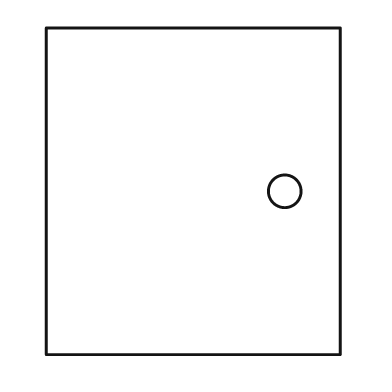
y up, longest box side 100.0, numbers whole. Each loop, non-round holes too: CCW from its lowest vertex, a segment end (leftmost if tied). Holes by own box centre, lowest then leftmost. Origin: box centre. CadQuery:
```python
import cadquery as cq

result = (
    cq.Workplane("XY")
    .moveTo(-45.0, -50.0)
    .lineTo(45.0, -50.0)
    .lineTo(45.0, 50.0)
    .lineTo(-45.0, 50.0)
    .close()
    .moveTo(28.0, 0.0)
    .circle(5.0)
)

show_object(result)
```